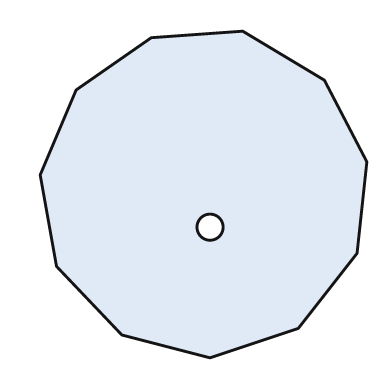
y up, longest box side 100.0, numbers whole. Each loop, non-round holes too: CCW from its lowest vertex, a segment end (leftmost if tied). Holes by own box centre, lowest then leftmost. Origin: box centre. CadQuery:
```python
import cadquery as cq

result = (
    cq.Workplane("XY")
    .moveTo(2.0, -50.0)
    .lineTo(29.0, -41.0)
    .lineTo(47.0, -18.0)
    .lineTo(50.0, 10.0)
    .lineTo(37.0, 35.0)
    .lineTo(12.0, 50.0)
    .lineTo(-16.0, 48.0)
    .lineTo(-39.0, 32.0)
    .lineTo(-50.0, 6.0)
    .lineTo(-45.0, -22.0)
    .lineTo(-25.0, -43.0)
    .close()
    .moveTo(2.0, -10.0)
    .circle(4.0)
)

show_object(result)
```